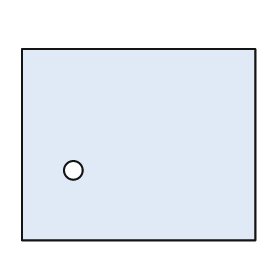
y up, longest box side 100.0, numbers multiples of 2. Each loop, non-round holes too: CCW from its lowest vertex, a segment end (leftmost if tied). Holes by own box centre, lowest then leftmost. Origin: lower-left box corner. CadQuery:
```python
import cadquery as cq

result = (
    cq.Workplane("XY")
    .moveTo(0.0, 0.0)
    .lineTo(100.0, 0.0)
    .lineTo(100.0, 82.0)
    .lineTo(0.0, 82.0)
    .close()
    .moveTo(22.0, 30.0)
    .circle(4.0)
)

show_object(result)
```